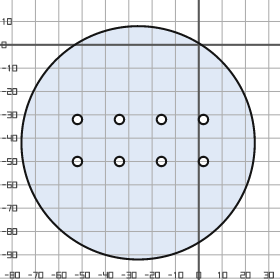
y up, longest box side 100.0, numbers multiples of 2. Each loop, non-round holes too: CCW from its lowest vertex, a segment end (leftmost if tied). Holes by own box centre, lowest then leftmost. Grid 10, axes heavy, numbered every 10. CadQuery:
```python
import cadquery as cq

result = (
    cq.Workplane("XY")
    .moveTo(-26.0, -42.0)
    .circle(50.0)
    .moveTo(-52.0, -50.0)
    .circle(2.0)
    .moveTo(-34.0, -50.0)
    .circle(2.0)
    .moveTo(-16.0, -50.0)
    .circle(2.0)
    .moveTo(2.0, -50.0)
    .circle(2.0)
    .moveTo(-52.0, -32.0)
    .circle(2.0)
    .moveTo(-34.0, -32.0)
    .circle(2.0)
    .moveTo(-16.0, -32.0)
    .circle(2.0)
    .moveTo(2.0, -32.0)
    .circle(2.0)
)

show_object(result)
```